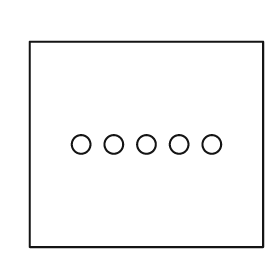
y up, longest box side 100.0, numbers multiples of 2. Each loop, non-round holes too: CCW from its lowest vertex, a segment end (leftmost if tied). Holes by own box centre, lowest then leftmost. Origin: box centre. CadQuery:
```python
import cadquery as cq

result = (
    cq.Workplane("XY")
    .moveTo(-50.0, -44.0)
    .lineTo(50.0, -44.0)
    .lineTo(50.0, 44.0)
    .lineTo(-50.0, 44.0)
    .close()
    .moveTo(-28.0, 0.0)
    .circle(4.0)
    .moveTo(-14.0, 0.0)
    .circle(4.0)
    .moveTo(0.0, 0.0)
    .circle(4.0)
    .moveTo(14.0, 0.0)
    .circle(4.0)
    .moveTo(28.0, 0.0)
    .circle(4.0)
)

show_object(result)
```